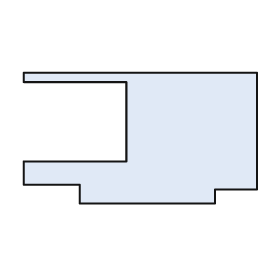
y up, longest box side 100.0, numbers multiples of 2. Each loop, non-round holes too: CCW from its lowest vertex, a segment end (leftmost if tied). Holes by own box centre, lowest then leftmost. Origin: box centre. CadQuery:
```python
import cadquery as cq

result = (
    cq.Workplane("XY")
    .moveTo(-26.0, -28.0)
    .lineTo(32.0, -28.0)
    .lineTo(32.0, -22.0)
    .lineTo(50.0, -22.0)
    .lineTo(50.0, 28.0)
    .lineTo(-50.0, 28.0)
    .lineTo(-50.0, 24.0)
    .lineTo(-6.0, 24.0)
    .lineTo(-6.0, -10.0)
    .lineTo(-50.0, -10.0)
    .lineTo(-50.0, -20.0)
    .lineTo(-26.0, -20.0)
    .close()
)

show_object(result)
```